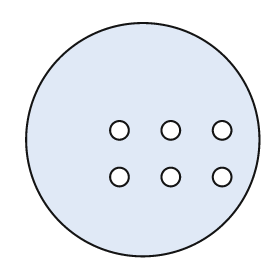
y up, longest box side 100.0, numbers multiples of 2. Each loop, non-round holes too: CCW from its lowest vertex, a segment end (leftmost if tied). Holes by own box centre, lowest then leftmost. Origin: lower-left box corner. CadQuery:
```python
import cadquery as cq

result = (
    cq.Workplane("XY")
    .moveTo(50.0, 50.0)
    .circle(50.0)
    .moveTo(40.0, 34.0)
    .circle(4.0)
    .moveTo(62.0, 34.0)
    .circle(4.0)
    .moveTo(84.0, 34.0)
    .circle(4.0)
    .moveTo(40.0, 54.0)
    .circle(4.0)
    .moveTo(62.0, 54.0)
    .circle(4.0)
    .moveTo(84.0, 54.0)
    .circle(4.0)
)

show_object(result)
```